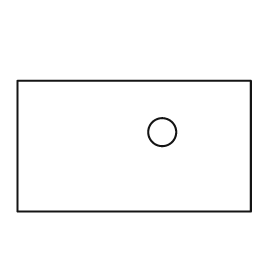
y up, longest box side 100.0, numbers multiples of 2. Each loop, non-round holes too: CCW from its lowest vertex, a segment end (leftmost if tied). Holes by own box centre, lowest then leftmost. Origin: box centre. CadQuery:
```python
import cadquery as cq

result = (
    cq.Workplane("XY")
    .moveTo(-50.0, -28.0)
    .lineTo(50.0, -28.0)
    .lineTo(50.0, 28.0)
    .lineTo(-50.0, 28.0)
    .close()
    .moveTo(12.0, 6.0)
    .circle(6.0)
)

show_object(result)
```